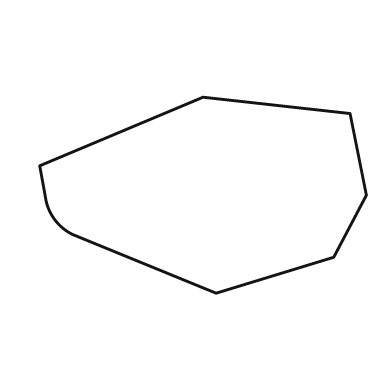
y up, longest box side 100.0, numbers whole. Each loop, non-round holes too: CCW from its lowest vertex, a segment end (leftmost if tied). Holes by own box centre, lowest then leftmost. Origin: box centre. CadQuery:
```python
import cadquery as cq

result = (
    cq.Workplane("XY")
    .moveTo(4.0, -30.0)
    .lineTo(40.0, -19.0)
    .lineTo(50.0, 0.0)
    .lineTo(45.0, 25.0)
    .lineTo(0.0, 30.0)
    .lineTo(-50.0, 9.0)
    .lineTo(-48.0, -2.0)
    .threePointArc((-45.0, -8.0), (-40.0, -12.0))
    .close()
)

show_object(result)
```